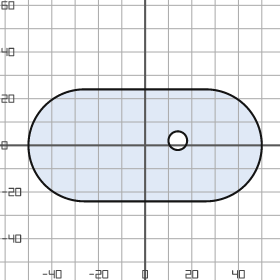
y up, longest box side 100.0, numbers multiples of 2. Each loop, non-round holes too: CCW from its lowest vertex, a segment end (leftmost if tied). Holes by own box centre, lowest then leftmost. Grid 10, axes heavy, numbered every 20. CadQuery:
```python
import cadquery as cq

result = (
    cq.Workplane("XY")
    .moveTo(-26.0, -24.0)
    .lineTo(26.0, -24.0)
    .threePointArc((50.0, 0.0), (26.0, 24.0))
    .lineTo(-26.0, 24.0)
    .threePointArc((-50.0, 0.0), (-26.0, -24.0))
    .close()
    .moveTo(14.0, 2.0)
    .circle(4.0)
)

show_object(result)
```